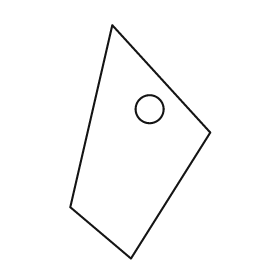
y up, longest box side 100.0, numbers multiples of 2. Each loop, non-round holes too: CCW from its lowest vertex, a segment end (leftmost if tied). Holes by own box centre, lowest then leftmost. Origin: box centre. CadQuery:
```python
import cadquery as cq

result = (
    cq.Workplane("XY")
    .moveTo(-4.0, -50.0)
    .lineTo(30.0, 4.0)
    .lineTo(-12.0, 50.0)
    .lineTo(-30.0, -28.0)
    .close()
    .moveTo(4.0, 14.0)
    .circle(6.0)
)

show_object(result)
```